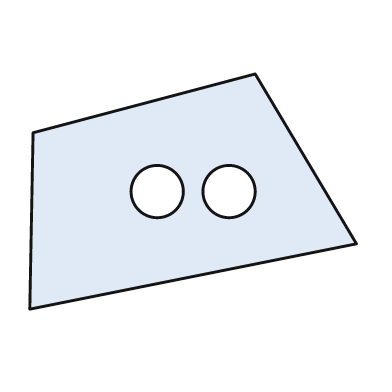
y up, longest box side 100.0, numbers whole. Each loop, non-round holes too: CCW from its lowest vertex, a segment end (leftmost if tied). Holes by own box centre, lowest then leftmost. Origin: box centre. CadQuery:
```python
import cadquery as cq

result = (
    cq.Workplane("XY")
    .moveTo(-50.0, -36.0)
    .lineTo(50.0, -16.0)
    .lineTo(19.0, 36.0)
    .lineTo(-49.0, 18.0)
    .close()
    .moveTo(-11.0, 0.0)
    .circle(8.0)
    .moveTo(11.0, 0.0)
    .circle(8.0)
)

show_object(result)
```